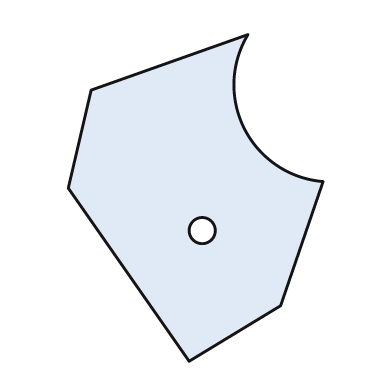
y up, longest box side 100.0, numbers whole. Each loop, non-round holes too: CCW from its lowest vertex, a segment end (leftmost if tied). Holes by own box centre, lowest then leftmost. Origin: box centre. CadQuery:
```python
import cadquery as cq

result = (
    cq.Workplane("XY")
    .moveTo(-2.0, -50.0)
    .lineTo(26.0, -33.0)
    .lineTo(39.0, 5.0)
    .threePointArc((15.0, 21.0), (16.0, 50.0))
    .lineTo(-32.0, 33.0)
    .lineTo(-39.0, 3.0)
    .close()
    .moveTo(2.0, -10.0)
    .circle(4.0)
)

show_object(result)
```